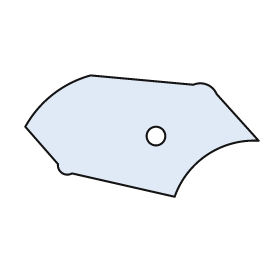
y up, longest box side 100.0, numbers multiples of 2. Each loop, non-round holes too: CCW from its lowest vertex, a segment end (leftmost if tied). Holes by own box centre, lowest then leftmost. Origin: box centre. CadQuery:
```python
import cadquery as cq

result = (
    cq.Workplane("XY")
    .moveTo(14.0, -26.0)
    .threePointArc((28.0, -8.0), (50.0, -2.0))
    .lineTo(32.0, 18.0)
    .threePointArc((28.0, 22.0), (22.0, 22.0))
    .lineTo(-22.0, 26.0)
    .threePointArc((-38.0, 18.0), (-50.0, 4.0))
    .lineTo(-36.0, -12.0)
    .threePointArc((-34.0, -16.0), (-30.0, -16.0))
    .close()
    .moveTo(6.0, 0.0)
    .circle(4.0)
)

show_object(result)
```